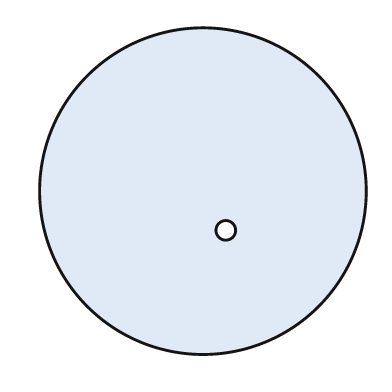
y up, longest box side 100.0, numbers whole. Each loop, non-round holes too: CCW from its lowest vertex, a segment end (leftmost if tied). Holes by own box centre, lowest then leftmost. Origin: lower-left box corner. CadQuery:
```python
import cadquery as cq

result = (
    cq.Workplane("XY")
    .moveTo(50.0, 50.0)
    .circle(50.0)
    .moveTo(57.0, 38.0)
    .circle(3.0)
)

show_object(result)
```